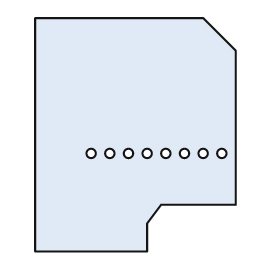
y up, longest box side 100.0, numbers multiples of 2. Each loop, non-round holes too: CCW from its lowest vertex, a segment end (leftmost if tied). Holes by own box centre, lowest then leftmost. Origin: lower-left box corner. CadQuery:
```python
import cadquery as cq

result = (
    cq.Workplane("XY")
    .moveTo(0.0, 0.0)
    .lineTo(48.0, 0.0)
    .lineTo(48.0, 12.0)
    .lineTo(54.0, 20.0)
    .lineTo(86.0, 20.0)
    .lineTo(86.0, 86.0)
    .lineTo(72.0, 100.0)
    .lineTo(0.0, 100.0)
    .close()
    .moveTo(24.0, 42.0)
    .circle(2.0)
    .moveTo(32.0, 42.0)
    .circle(2.0)
    .moveTo(40.0, 42.0)
    .circle(2.0)
    .moveTo(48.0, 42.0)
    .circle(2.0)
    .moveTo(56.0, 42.0)
    .circle(2.0)
    .moveTo(64.0, 42.0)
    .circle(2.0)
    .moveTo(72.0, 42.0)
    .circle(2.0)
    .moveTo(80.0, 42.0)
    .circle(2.0)
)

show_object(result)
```